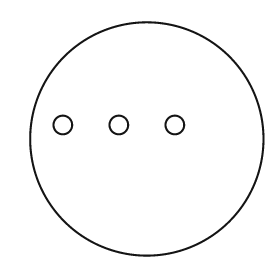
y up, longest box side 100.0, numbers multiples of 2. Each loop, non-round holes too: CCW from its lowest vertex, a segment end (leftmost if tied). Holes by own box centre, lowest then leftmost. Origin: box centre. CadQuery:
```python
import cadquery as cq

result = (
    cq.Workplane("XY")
    .moveTo(0.0, 0.0)
    .circle(50.0)
    .moveTo(-36.0, 6.0)
    .circle(4.0)
    .moveTo(-12.0, 6.0)
    .circle(4.0)
    .moveTo(12.0, 6.0)
    .circle(4.0)
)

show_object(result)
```